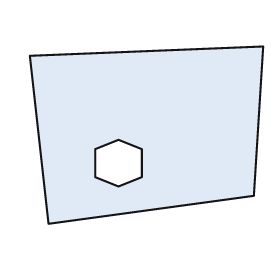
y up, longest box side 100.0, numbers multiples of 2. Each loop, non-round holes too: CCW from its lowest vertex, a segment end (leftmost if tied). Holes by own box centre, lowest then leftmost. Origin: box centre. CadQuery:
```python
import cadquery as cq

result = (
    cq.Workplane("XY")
    .moveTo(-42.0, -38.0)
    .lineTo(46.0, -26.0)
    .lineTo(50.0, 38.0)
    .lineTo(-50.0, 34.0)
    .close()
    .moveTo(-12.0, -22.0)
    .lineTo(-2.0, -18.0)
    .lineTo(-2.0, -6.0)
    .lineTo(-12.0, -2.0)
    .lineTo(-22.0, -6.0)
    .lineTo(-22.0, -18.0)
    .close()
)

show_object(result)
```